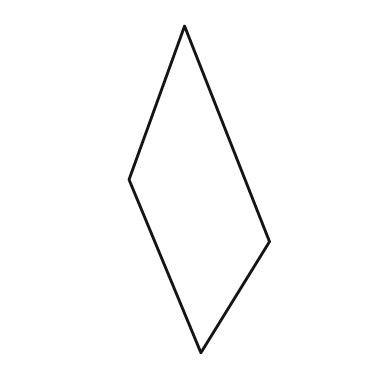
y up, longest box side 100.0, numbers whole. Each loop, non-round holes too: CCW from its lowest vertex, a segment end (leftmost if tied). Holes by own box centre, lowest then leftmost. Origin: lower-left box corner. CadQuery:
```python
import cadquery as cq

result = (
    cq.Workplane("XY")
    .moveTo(22.0, 0.0)
    .lineTo(43.0, 34.0)
    .lineTo(17.0, 100.0)
    .lineTo(0.0, 53.0)
    .close()
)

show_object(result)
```